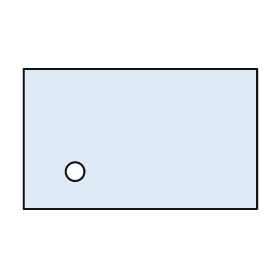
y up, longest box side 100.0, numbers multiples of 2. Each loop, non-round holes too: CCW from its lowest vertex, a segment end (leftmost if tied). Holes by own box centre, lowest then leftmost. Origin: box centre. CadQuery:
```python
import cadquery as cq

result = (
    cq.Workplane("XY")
    .moveTo(-50.0, -30.0)
    .lineTo(50.0, -30.0)
    .lineTo(50.0, 30.0)
    .lineTo(-50.0, 30.0)
    .close()
    .moveTo(-28.0, -14.0)
    .circle(4.0)
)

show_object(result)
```